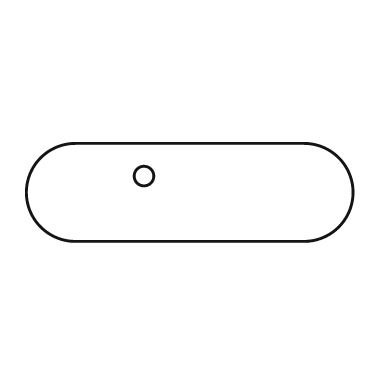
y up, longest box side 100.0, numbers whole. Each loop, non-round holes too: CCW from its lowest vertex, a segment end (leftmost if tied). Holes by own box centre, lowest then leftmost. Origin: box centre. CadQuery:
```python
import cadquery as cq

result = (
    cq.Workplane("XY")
    .moveTo(-35.0, -15.0)
    .lineTo(35.0, -15.0)
    .threePointArc((50.0, 0.0), (35.0, 15.0))
    .lineTo(-35.0, 15.0)
    .threePointArc((-50.0, 0.0), (-35.0, -15.0))
    .close()
    .moveTo(-14.0, 5.0)
    .circle(3.0)
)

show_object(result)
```